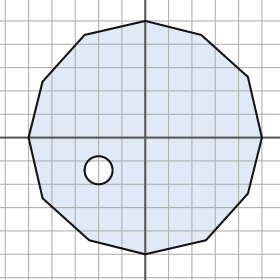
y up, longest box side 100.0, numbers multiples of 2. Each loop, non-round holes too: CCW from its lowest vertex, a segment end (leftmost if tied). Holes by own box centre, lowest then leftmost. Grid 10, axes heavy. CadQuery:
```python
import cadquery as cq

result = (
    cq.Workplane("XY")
    .moveTo(0.0, -50.0)
    .lineTo(26.0, -44.0)
    .lineTo(44.0, -24.0)
    .lineTo(50.0, 0.0)
    .lineTo(44.0, 26.0)
    .lineTo(24.0, 44.0)
    .lineTo(0.0, 50.0)
    .lineTo(-26.0, 44.0)
    .lineTo(-44.0, 24.0)
    .lineTo(-50.0, 0.0)
    .lineTo(-44.0, -26.0)
    .lineTo(-24.0, -44.0)
    .close()
    .moveTo(-20.0, -14.0)
    .circle(6.0)
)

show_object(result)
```